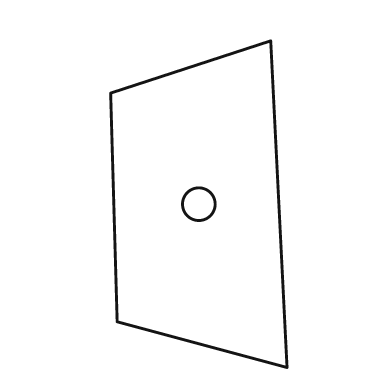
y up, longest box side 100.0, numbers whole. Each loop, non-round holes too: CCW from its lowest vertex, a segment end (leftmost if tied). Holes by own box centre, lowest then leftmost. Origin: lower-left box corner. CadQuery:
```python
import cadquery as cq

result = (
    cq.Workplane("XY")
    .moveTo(54.0, 0.0)
    .lineTo(49.0, 100.0)
    .lineTo(0.0, 84.0)
    .lineTo(2.0, 14.0)
    .close()
    .moveTo(27.0, 50.0)
    .circle(5.0)
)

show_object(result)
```